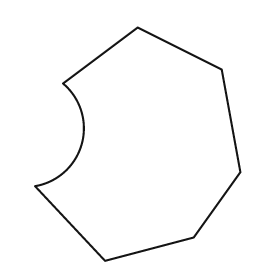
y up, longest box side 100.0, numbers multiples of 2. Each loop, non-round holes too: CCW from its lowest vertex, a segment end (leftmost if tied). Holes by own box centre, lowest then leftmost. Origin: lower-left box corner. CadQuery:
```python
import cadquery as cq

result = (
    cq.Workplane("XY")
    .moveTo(30.0, 0.0)
    .lineTo(68.0, 10.0)
    .lineTo(88.0, 38.0)
    .lineTo(80.0, 82.0)
    .lineTo(44.0, 100.0)
    .lineTo(12.0, 76.0)
    .threePointArc((20.0, 50.0), (0.0, 32.0))
    .close()
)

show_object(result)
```